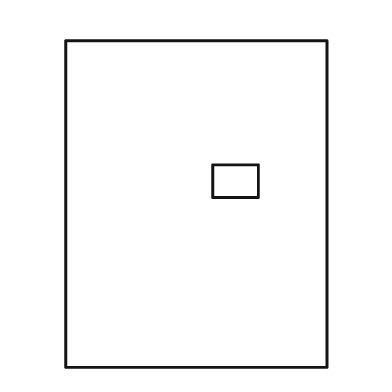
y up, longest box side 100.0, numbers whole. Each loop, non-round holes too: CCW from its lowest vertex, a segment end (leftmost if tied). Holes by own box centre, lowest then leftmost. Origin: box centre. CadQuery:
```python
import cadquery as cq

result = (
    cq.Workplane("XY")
    .moveTo(-40.0, -50.0)
    .lineTo(40.0, -50.0)
    .lineTo(40.0, 50.0)
    .lineTo(-40.0, 50.0)
    .close()
    .moveTo(5.0, 2.0)
    .lineTo(19.0, 2.0)
    .lineTo(19.0, 12.0)
    .lineTo(5.0, 12.0)
    .close()
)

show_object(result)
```